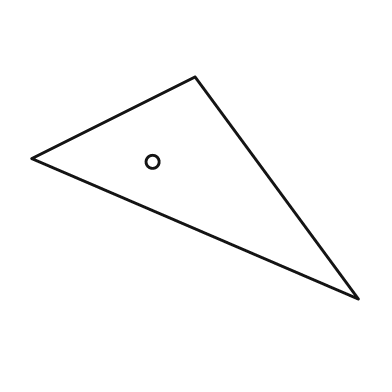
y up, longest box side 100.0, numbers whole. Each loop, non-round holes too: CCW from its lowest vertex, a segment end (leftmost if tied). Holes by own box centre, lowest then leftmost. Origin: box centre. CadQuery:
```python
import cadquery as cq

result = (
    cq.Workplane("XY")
    .moveTo(50.0, -34.0)
    .lineTo(0.0, 34.0)
    .lineTo(-50.0, 9.0)
    .close()
    .moveTo(-13.0, 8.0)
    .circle(2.0)
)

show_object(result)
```